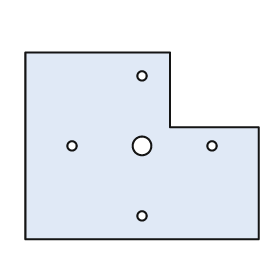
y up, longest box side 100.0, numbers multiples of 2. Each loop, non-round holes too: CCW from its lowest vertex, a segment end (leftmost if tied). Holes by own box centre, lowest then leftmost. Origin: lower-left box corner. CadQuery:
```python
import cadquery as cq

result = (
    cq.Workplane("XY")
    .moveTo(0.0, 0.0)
    .lineTo(100.0, 0.0)
    .lineTo(100.0, 48.0)
    .lineTo(62.0, 48.0)
    .lineTo(62.0, 80.0)
    .lineTo(0.0, 80.0)
    .close()
    .moveTo(50.0, 10.0)
    .circle(2.0)
    .moveTo(20.0, 40.0)
    .circle(2.0)
    .moveTo(50.0, 40.0)
    .circle(4.0)
    .moveTo(80.0, 40.0)
    .circle(2.0)
    .moveTo(50.0, 70.0)
    .circle(2.0)
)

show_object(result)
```